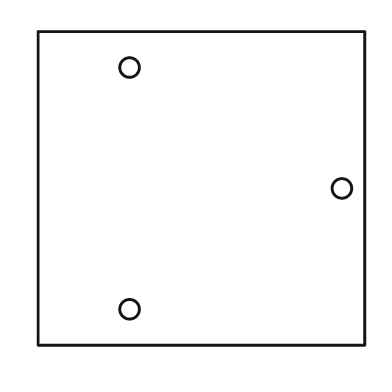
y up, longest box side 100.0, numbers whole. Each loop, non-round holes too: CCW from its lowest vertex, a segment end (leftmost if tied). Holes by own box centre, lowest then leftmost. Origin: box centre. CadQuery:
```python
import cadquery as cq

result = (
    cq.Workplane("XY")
    .moveTo(-50.0, -48.0)
    .lineTo(50.0, -48.0)
    .lineTo(50.0, 48.0)
    .lineTo(-50.0, 48.0)
    .close()
    .moveTo(-22.0, -37.0)
    .circle(3.0)
    .moveTo(43.0, 0.0)
    .circle(3.0)
    .moveTo(-22.0, 37.0)
    .circle(3.0)
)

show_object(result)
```